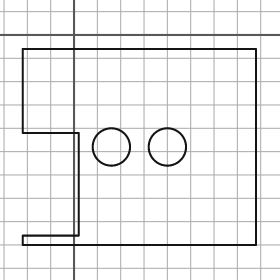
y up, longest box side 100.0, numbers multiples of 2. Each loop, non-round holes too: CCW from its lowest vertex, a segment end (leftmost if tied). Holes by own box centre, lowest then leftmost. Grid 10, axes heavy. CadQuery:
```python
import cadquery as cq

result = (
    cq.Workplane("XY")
    .moveTo(-22.0, -90.0)
    .lineTo(78.0, -90.0)
    .lineTo(78.0, -6.0)
    .lineTo(-22.0, -6.0)
    .lineTo(-22.0, -42.0)
    .lineTo(2.0, -42.0)
    .lineTo(2.0, -86.0)
    .lineTo(-22.0, -86.0)
    .close()
    .moveTo(16.0, -48.0)
    .circle(8.0)
    .moveTo(40.0, -48.0)
    .circle(8.0)
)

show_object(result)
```